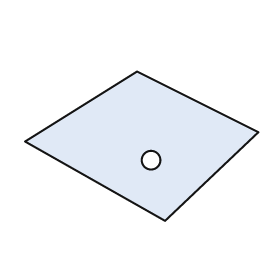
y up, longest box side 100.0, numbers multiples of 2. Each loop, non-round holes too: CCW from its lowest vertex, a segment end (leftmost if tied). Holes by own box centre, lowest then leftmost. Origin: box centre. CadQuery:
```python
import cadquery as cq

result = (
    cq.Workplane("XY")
    .moveTo(10.0, -32.0)
    .lineTo(50.0, 6.0)
    .lineTo(-2.0, 32.0)
    .lineTo(-50.0, 2.0)
    .close()
    .moveTo(4.0, -6.0)
    .circle(4.0)
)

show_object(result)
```